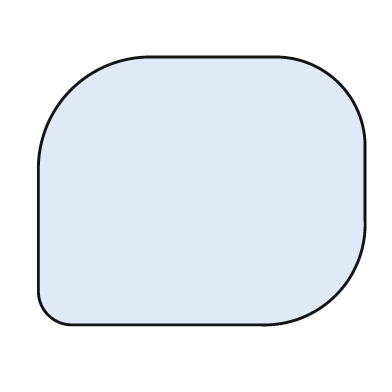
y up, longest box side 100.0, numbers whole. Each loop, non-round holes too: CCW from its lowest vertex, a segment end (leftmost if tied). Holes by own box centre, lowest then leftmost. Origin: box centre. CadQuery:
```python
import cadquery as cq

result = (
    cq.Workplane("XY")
    .moveTo(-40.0, -41.0)
    .lineTo(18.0, -41.0)
    .threePointArc((41.0, -32.0), (50.0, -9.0))
    .lineTo(50.0, 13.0)
    .threePointArc((42.0, 33.0), (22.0, 41.0))
    .lineTo(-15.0, 41.0)
    .threePointArc((-40.0, 31.0), (-50.0, 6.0))
    .lineTo(-50.0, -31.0)
    .threePointArc((-47.0, -38.0), (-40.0, -41.0))
    .close()
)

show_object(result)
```